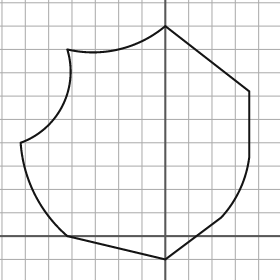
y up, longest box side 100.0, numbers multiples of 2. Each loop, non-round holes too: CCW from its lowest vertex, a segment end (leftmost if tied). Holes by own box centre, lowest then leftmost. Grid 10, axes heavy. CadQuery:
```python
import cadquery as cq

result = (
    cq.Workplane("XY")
    .moveTo(0.0, -10.0)
    .lineTo(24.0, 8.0)
    .threePointArc((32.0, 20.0), (36.0, 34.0))
    .lineTo(36.0, 62.0)
    .lineTo(0.0, 90.0)
    .threePointArc((-20.0, 80.0), (-42.0, 80.0))
    .threePointArc((-44.0, 56.0), (-62.0, 40.0))
    .threePointArc((-56.0, 18.0), (-42.0, 0.0))
    .close()
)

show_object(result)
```